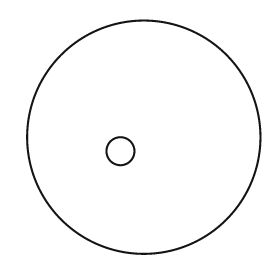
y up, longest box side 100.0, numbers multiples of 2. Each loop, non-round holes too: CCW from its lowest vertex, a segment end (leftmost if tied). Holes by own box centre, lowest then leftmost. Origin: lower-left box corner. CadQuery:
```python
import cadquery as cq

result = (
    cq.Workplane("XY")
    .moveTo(50.0, 50.0)
    .circle(50.0)
    .moveTo(40.0, 44.0)
    .circle(6.0)
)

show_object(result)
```